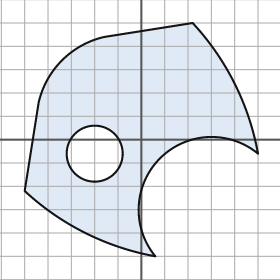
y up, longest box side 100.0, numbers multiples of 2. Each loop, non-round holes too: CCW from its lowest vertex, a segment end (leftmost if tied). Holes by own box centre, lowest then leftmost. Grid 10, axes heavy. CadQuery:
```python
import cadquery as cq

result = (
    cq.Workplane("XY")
    .moveTo(6.0, -50.0)
    .threePointArc((8.0, -8.0), (50.0, -6.0))
    .threePointArc((40.0, 24.0), (22.0, 50.0))
    .lineTo(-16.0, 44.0)
    .threePointArc((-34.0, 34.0), (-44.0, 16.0))
    .lineTo(-50.0, -22.0)
    .threePointArc((-24.0, -40.0), (6.0, -50.0))
    .close()
    .moveTo(-20.0, -6.0)
    .circle(12.0)
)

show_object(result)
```